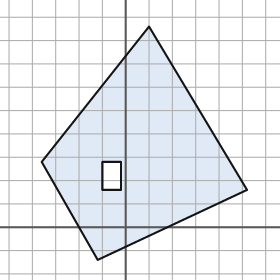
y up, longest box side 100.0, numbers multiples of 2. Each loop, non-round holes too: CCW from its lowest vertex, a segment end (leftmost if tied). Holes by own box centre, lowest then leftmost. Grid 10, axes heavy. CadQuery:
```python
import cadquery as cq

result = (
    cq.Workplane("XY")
    .moveTo(-12.0, -14.0)
    .lineTo(52.0, 16.0)
    .lineTo(10.0, 86.0)
    .lineTo(-36.0, 28.0)
    .close()
    .moveTo(-10.0, 16.0)
    .lineTo(-2.0, 16.0)
    .lineTo(-2.0, 28.0)
    .lineTo(-10.0, 28.0)
    .close()
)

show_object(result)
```